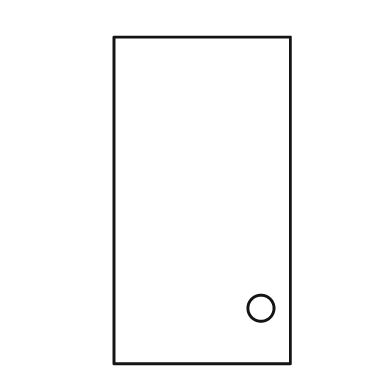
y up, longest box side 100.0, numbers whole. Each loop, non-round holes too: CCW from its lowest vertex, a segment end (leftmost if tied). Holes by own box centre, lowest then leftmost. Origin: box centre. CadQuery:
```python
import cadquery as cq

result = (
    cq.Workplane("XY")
    .moveTo(-27.0, -50.0)
    .lineTo(27.0, -50.0)
    .lineTo(27.0, 50.0)
    .lineTo(-27.0, 50.0)
    .close()
    .moveTo(18.0, -33.0)
    .circle(4.0)
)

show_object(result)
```